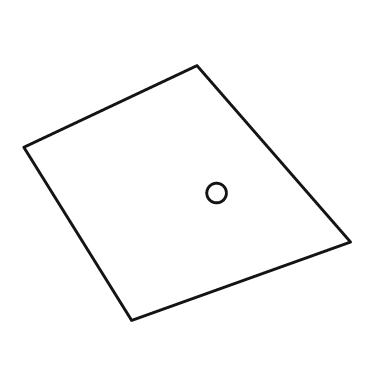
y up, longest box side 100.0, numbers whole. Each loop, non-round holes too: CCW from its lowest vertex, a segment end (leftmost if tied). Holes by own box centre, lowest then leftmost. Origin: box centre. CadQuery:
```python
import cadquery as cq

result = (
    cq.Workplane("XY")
    .moveTo(-17.0, -39.0)
    .lineTo(50.0, -15.0)
    .lineTo(3.0, 39.0)
    .lineTo(-50.0, 14.0)
    .close()
    .moveTo(9.0, 0.0)
    .circle(3.0)
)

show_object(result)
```